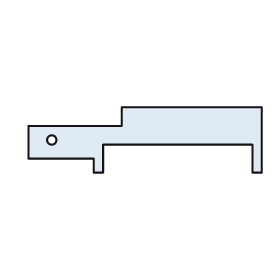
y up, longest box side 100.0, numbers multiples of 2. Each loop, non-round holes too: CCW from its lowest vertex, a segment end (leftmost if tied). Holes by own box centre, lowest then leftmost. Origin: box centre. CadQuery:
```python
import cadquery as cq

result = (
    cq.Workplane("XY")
    .moveTo(-22.0, -14.0)
    .lineTo(-18.0, -14.0)
    .lineTo(-18.0, -2.0)
    .lineTo(46.0, -2.0)
    .lineTo(46.0, -14.0)
    .lineTo(50.0, -14.0)
    .lineTo(50.0, 14.0)
    .lineTo(-10.0, 14.0)
    .lineTo(-10.0, 6.0)
    .lineTo(-50.0, 6.0)
    .lineTo(-50.0, -8.0)
    .lineTo(-22.0, -8.0)
    .close()
    .moveTo(-40.0, 0.0)
    .circle(2.0)
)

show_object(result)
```